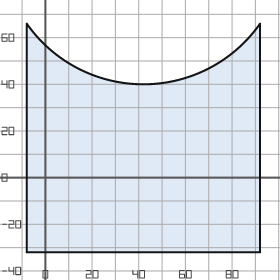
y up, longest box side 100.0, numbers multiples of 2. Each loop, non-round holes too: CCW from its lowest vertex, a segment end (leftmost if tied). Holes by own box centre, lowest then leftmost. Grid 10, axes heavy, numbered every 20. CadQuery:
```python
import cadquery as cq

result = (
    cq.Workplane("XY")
    .moveTo(-8.0, -32.0)
    .lineTo(92.0, -32.0)
    .lineTo(92.0, 66.0)
    .threePointArc((42.0, 40.0), (-8.0, 66.0))
    .close()
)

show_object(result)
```